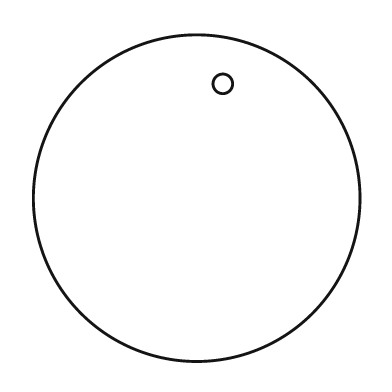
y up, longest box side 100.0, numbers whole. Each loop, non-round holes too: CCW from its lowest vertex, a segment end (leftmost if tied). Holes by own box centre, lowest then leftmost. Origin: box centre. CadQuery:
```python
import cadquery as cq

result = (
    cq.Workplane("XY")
    .moveTo(0.0, 0.0)
    .circle(50.0)
    .moveTo(8.0, 35.0)
    .circle(3.0)
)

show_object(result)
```